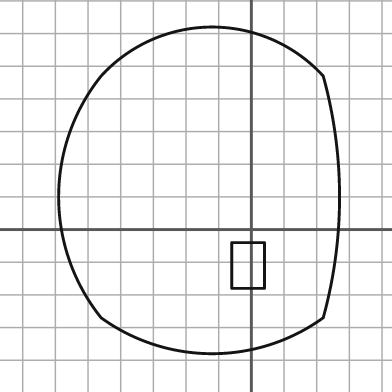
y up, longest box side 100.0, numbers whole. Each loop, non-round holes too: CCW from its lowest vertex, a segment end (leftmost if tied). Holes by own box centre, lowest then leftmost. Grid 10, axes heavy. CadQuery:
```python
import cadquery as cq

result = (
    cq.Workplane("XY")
    .moveTo(-46.0, -27.0)
    .threePointArc((-12.0, -38.0), (22.0, -27.0))
    .threePointArc((27.0, 10.0), (22.0, 47.0))
    .threePointArc((-12.0, 62.0), (-46.0, 47.0))
    .threePointArc((-59.0, 10.0), (-46.0, -27.0))
    .close()
    .moveTo(-6.0, -18.0)
    .lineTo(4.0, -18.0)
    .lineTo(4.0, -4.0)
    .lineTo(-6.0, -4.0)
    .close()
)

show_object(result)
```